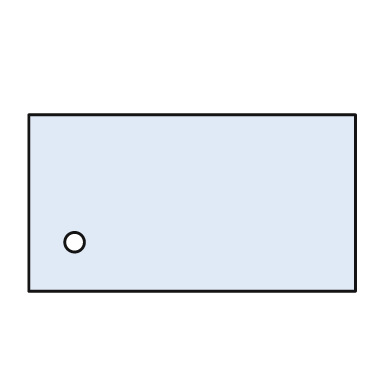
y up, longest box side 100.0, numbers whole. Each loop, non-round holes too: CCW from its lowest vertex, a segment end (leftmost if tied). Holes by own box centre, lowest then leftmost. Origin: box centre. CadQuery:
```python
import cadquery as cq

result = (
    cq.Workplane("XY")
    .moveTo(-50.0, -27.0)
    .lineTo(50.0, -27.0)
    .lineTo(50.0, 27.0)
    .lineTo(-50.0, 27.0)
    .close()
    .moveTo(-36.0, -12.0)
    .circle(3.0)
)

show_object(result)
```